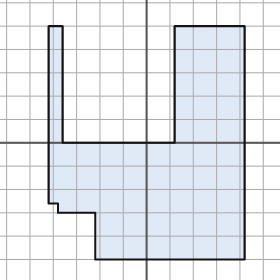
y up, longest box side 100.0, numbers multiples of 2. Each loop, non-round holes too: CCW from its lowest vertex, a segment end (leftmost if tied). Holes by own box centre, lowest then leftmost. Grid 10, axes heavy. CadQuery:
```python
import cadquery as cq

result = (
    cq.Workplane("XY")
    .moveTo(-22.0, -50.0)
    .lineTo(42.0, -50.0)
    .lineTo(42.0, 50.0)
    .lineTo(12.0, 50.0)
    .lineTo(12.0, 0.0)
    .lineTo(-36.0, 0.0)
    .lineTo(-36.0, 50.0)
    .lineTo(-42.0, 50.0)
    .lineTo(-42.0, -26.0)
    .lineTo(-38.0, -26.0)
    .lineTo(-38.0, -30.0)
    .lineTo(-22.0, -30.0)
    .close()
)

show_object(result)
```